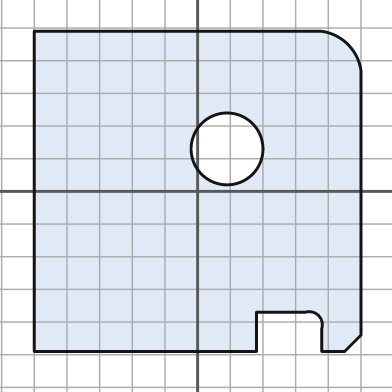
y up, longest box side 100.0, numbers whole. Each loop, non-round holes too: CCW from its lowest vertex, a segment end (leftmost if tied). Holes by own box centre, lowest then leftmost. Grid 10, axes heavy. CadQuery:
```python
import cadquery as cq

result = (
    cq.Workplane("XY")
    .moveTo(-50.0, -49.0)
    .lineTo(18.0, -49.0)
    .lineTo(18.0, -37.0)
    .lineTo(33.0, -37.0)
    .threePointArc((37.0, -38.0), (38.0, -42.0))
    .lineTo(38.0, -49.0)
    .lineTo(45.0, -49.0)
    .lineTo(50.0, -44.0)
    .lineTo(50.0, 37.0)
    .threePointArc((46.0, 45.0), (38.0, 49.0))
    .lineTo(-50.0, 49.0)
    .close()
    .moveTo(9.0, 13.0)
    .circle(11.0)
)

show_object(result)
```